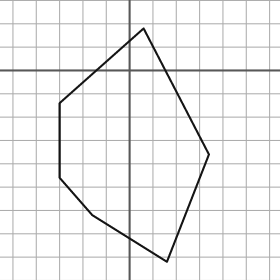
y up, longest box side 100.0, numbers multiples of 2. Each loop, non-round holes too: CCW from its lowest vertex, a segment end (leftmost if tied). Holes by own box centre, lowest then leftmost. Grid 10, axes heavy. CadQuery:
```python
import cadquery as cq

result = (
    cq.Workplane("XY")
    .moveTo(16.0, -82.0)
    .lineTo(34.0, -36.0)
    .lineTo(6.0, 18.0)
    .lineTo(-30.0, -14.0)
    .lineTo(-30.0, -46.0)
    .lineTo(-16.0, -62.0)
    .close()
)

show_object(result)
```